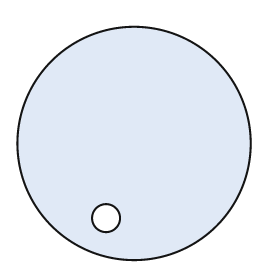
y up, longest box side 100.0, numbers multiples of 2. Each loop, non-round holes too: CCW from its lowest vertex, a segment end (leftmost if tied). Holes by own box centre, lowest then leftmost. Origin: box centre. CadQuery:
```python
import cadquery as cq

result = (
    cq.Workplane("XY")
    .moveTo(0.0, 0.0)
    .circle(50.0)
    .moveTo(-12.0, -32.0)
    .circle(6.0)
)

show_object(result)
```